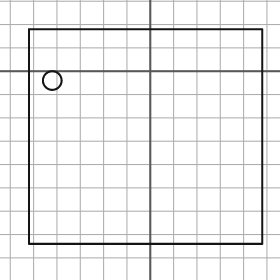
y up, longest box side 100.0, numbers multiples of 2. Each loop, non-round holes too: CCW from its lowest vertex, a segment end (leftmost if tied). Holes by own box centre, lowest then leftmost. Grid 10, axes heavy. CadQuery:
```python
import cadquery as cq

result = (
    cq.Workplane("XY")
    .moveTo(-52.0, -74.0)
    .lineTo(48.0, -74.0)
    .lineTo(48.0, 18.0)
    .lineTo(-52.0, 18.0)
    .close()
    .moveTo(-42.0, -4.0)
    .circle(4.0)
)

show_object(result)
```